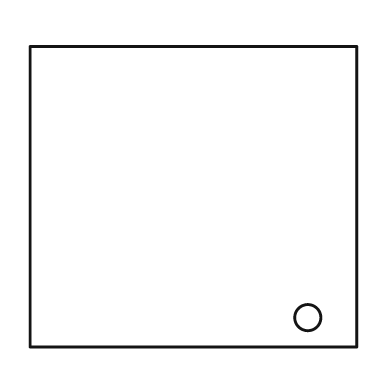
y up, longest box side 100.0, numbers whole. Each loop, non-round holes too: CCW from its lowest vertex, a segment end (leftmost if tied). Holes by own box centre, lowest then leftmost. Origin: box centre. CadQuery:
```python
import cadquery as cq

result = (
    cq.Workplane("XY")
    .moveTo(-50.0, -46.0)
    .lineTo(50.0, -46.0)
    .lineTo(50.0, 46.0)
    .lineTo(-50.0, 46.0)
    .close()
    .moveTo(35.0, -37.0)
    .circle(4.0)
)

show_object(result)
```